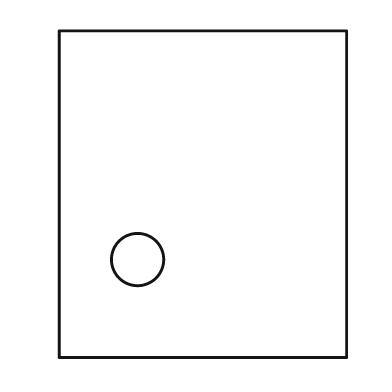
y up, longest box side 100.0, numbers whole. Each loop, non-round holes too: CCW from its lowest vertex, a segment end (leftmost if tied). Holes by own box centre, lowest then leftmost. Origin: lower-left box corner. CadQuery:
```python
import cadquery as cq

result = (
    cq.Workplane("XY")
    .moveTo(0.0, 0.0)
    .lineTo(88.0, 0.0)
    .lineTo(88.0, 100.0)
    .lineTo(0.0, 100.0)
    .close()
    .moveTo(24.0, 30.0)
    .circle(8.0)
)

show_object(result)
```